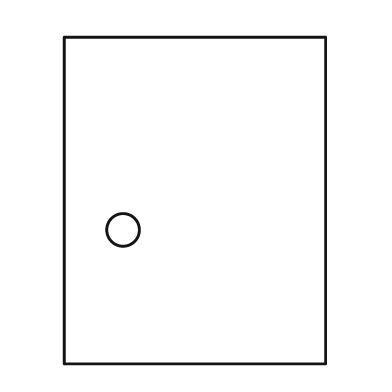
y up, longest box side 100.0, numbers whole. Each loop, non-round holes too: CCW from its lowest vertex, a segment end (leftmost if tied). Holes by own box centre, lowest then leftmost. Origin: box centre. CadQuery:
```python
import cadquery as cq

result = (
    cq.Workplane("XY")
    .moveTo(-40.0, -50.0)
    .lineTo(40.0, -50.0)
    .lineTo(40.0, 50.0)
    .lineTo(-40.0, 50.0)
    .close()
    .moveTo(-22.0, -9.0)
    .circle(5.0)
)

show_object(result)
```